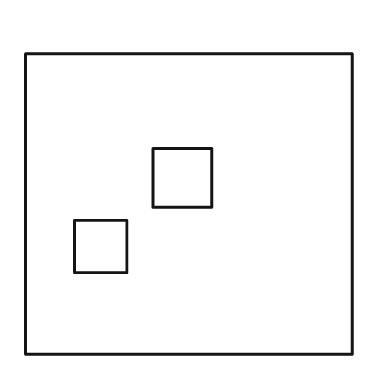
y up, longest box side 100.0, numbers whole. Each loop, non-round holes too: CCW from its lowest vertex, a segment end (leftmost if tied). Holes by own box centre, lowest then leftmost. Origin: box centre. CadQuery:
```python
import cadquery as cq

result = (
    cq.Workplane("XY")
    .moveTo(-50.0, -46.0)
    .lineTo(50.0, -46.0)
    .lineTo(50.0, 46.0)
    .lineTo(-50.0, 46.0)
    .close()
    .moveTo(-35.0, -21.0)
    .lineTo(-19.0, -21.0)
    .lineTo(-19.0, -5.0)
    .lineTo(-35.0, -5.0)
    .close()
    .moveTo(-11.0, -1.0)
    .lineTo(7.0, -1.0)
    .lineTo(7.0, 17.0)
    .lineTo(-11.0, 17.0)
    .close()
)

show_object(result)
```